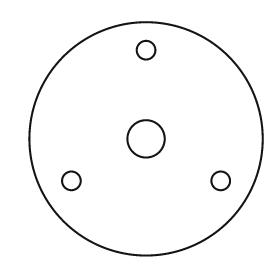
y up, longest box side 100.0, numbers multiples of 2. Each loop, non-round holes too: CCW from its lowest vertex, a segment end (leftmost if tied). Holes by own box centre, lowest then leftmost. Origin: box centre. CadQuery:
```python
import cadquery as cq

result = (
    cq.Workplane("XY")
    .moveTo(0.0, 0.0)
    .circle(50.0)
    .moveTo(-32.0, -18.0)
    .circle(4.0)
    .moveTo(32.0, -18.0)
    .circle(4.0)
    .moveTo(0.0, 0.0)
    .circle(8.0)
    .moveTo(0.0, 38.0)
    .circle(4.0)
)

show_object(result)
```